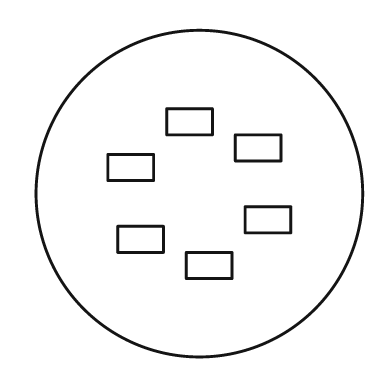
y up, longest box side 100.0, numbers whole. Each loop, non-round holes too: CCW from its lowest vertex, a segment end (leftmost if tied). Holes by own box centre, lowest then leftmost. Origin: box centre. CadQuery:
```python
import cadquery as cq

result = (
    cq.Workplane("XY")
    .moveTo(0.0, 0.0)
    .circle(50.0)
    .moveTo(-4.0, -26.0)
    .lineTo(10.0, -26.0)
    .lineTo(10.0, -18.0)
    .lineTo(-4.0, -18.0)
    .close()
    .moveTo(-25.0, -18.0)
    .lineTo(-11.0, -18.0)
    .lineTo(-11.0, -10.0)
    .lineTo(-25.0, -10.0)
    .close()
    .moveTo(14.0, -12.0)
    .lineTo(28.0, -12.0)
    .lineTo(28.0, -4.0)
    .lineTo(14.0, -4.0)
    .close()
    .moveTo(-28.0, 4.0)
    .lineTo(-14.0, 4.0)
    .lineTo(-14.0, 12.0)
    .lineTo(-28.0, 12.0)
    .close()
    .moveTo(11.0, 10.0)
    .lineTo(25.0, 10.0)
    .lineTo(25.0, 18.0)
    .lineTo(11.0, 18.0)
    .close()
    .moveTo(-10.0, 18.0)
    .lineTo(4.0, 18.0)
    .lineTo(4.0, 26.0)
    .lineTo(-10.0, 26.0)
    .close()
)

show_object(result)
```